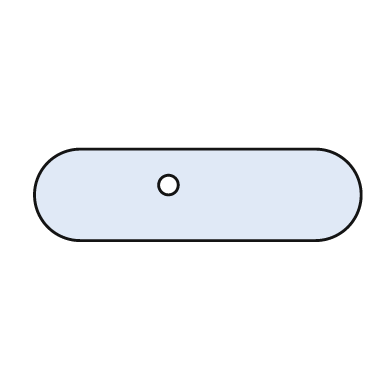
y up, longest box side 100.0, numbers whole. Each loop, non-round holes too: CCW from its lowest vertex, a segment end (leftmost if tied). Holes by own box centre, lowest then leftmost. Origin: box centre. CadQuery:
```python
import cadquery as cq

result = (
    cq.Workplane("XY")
    .moveTo(-36.0, -14.0)
    .lineTo(36.0, -14.0)
    .threePointArc((50.0, 0.0), (36.0, 14.0))
    .lineTo(-36.0, 14.0)
    .threePointArc((-50.0, 0.0), (-36.0, -14.0))
    .close()
    .moveTo(-9.0, 3.0)
    .circle(3.0)
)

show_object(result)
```